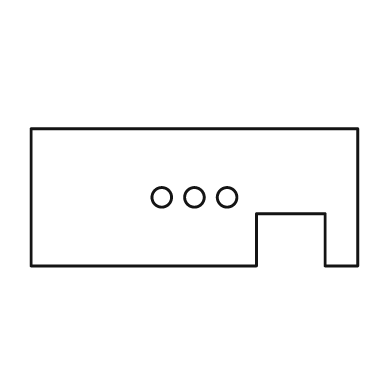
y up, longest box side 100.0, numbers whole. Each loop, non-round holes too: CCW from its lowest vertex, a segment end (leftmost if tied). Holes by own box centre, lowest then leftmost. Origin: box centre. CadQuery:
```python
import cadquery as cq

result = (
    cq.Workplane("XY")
    .moveTo(-50.0, -21.0)
    .lineTo(19.0, -21.0)
    .lineTo(19.0, -5.0)
    .lineTo(40.0, -5.0)
    .lineTo(40.0, -21.0)
    .lineTo(50.0, -21.0)
    .lineTo(50.0, 21.0)
    .lineTo(-50.0, 21.0)
    .close()
    .moveTo(-10.0, 0.0)
    .circle(3.0)
    .moveTo(0.0, 0.0)
    .circle(3.0)
    .moveTo(10.0, 0.0)
    .circle(3.0)
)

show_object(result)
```